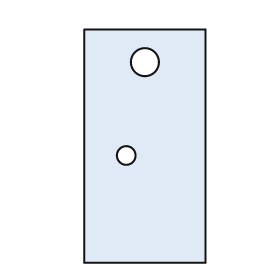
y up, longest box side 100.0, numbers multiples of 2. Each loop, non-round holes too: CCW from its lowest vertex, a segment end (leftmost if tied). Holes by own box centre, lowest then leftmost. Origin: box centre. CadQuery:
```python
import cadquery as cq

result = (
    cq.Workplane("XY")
    .moveTo(-26.0, -50.0)
    .lineTo(26.0, -50.0)
    .lineTo(26.0, 50.0)
    .lineTo(-26.0, 50.0)
    .close()
    .moveTo(-8.0, -4.0)
    .circle(4.0)
    .moveTo(0.0, 36.0)
    .circle(6.0)
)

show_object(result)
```